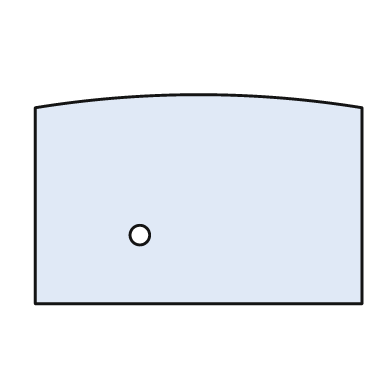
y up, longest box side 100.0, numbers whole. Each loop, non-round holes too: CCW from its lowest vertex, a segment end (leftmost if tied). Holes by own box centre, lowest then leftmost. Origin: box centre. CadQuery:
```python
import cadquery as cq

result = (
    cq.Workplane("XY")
    .moveTo(-50.0, -32.0)
    .lineTo(50.0, -32.0)
    .lineTo(50.0, 28.0)
    .threePointArc((0.0, 32.0), (-50.0, 28.0))
    .close()
    .moveTo(-18.0, -11.0)
    .circle(3.0)
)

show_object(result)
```